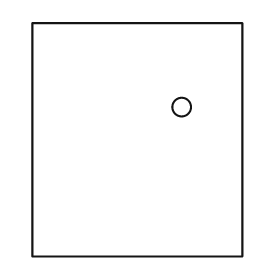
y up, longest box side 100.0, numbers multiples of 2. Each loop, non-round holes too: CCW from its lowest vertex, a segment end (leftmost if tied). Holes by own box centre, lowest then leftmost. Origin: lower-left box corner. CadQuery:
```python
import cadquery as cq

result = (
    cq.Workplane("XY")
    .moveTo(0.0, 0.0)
    .lineTo(90.0, 0.0)
    .lineTo(90.0, 100.0)
    .lineTo(0.0, 100.0)
    .close()
    .moveTo(64.0, 64.0)
    .circle(4.0)
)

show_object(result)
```